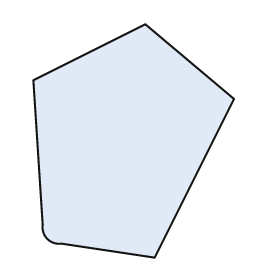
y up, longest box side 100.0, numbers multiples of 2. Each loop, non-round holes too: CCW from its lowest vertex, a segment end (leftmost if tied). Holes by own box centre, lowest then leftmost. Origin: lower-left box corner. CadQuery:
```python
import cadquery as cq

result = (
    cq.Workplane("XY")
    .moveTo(52.0, 0.0)
    .lineTo(86.0, 68.0)
    .lineTo(48.0, 100.0)
    .lineTo(0.0, 76.0)
    .lineTo(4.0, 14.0)
    .threePointArc((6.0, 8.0), (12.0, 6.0))
    .close()
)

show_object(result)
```